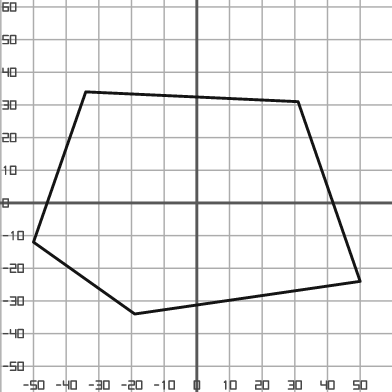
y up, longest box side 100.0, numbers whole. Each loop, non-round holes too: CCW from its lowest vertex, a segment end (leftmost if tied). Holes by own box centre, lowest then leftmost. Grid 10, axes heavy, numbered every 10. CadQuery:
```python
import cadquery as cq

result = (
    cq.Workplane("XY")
    .moveTo(-19.0, -34.0)
    .lineTo(50.0, -24.0)
    .lineTo(31.0, 31.0)
    .lineTo(-34.0, 34.0)
    .lineTo(-50.0, -12.0)
    .close()
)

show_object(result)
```